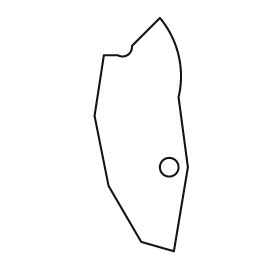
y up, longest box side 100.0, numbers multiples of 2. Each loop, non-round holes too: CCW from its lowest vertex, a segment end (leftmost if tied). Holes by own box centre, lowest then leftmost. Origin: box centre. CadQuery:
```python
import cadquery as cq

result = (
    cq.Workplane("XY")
    .moveTo(14.0, -50.0)
    .lineTo(20.0, -14.0)
    .lineTo(16.0, 16.0)
    .threePointArc((16.0, 34.0), (8.0, 50.0))
    .lineTo(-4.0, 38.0)
    .threePointArc((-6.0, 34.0), (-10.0, 34.0))
    .lineTo(-16.0, 34.0)
    .lineTo(-20.0, 8.0)
    .lineTo(-14.0, -22.0)
    .lineTo(0.0, -46.0)
    .close()
    .moveTo(12.0, -14.0)
    .circle(4.0)
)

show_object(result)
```